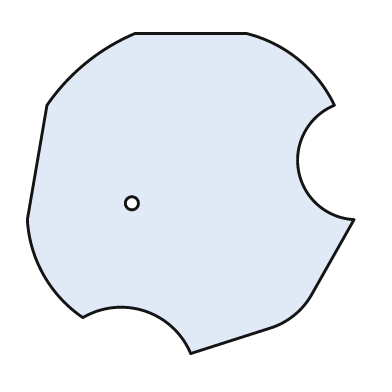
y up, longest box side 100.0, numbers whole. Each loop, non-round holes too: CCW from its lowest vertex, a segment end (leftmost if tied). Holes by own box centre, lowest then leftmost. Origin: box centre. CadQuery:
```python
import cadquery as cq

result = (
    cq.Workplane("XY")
    .moveTo(0.0, -49.0)
    .lineTo(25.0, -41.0)
    .threePointArc((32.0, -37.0), (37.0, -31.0))
    .lineTo(50.0, -8.0)
    .threePointArc((33.0, 7.0), (44.0, 27.0))
    .threePointArc((33.0, 41.0), (17.0, 49.0))
    .lineTo(-17.0, 49.0)
    .threePointArc((-32.0, 40.0), (-44.0, 27.0))
    .lineTo(-50.0, -8.0)
    .threePointArc((-45.0, -25.0), (-33.0, -38.0))
    .threePointArc((-14.0, -36.0), (0.0, -49.0))
    .close()
    .moveTo(-18.0, -3.0)
    .circle(2.0)
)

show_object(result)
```